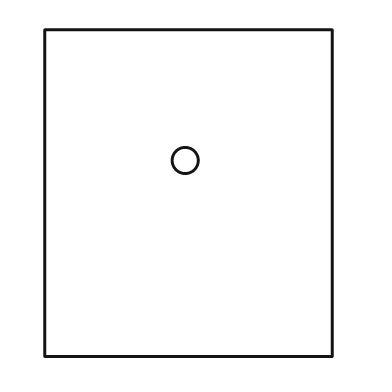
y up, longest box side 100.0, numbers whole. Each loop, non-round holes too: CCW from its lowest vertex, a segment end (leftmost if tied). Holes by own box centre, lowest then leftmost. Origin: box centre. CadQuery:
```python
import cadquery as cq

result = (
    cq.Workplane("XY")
    .moveTo(-44.0, -50.0)
    .lineTo(44.0, -50.0)
    .lineTo(44.0, 50.0)
    .lineTo(-44.0, 50.0)
    .close()
    .moveTo(-1.0, 10.0)
    .circle(4.0)
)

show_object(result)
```